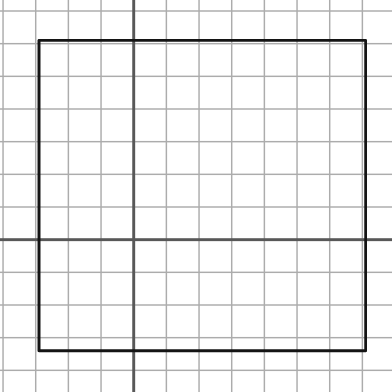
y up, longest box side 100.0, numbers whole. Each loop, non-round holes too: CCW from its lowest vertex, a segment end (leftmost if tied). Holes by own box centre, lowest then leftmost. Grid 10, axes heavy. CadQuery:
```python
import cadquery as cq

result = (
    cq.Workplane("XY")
    .moveTo(-29.0, -34.0)
    .lineTo(71.0, -34.0)
    .lineTo(71.0, 61.0)
    .lineTo(-29.0, 61.0)
    .close()
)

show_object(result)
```